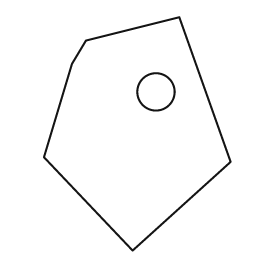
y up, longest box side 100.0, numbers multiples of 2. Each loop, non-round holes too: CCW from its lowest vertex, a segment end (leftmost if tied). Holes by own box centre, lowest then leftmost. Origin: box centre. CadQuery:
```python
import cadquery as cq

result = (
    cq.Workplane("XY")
    .moveTo(-2.0, -50.0)
    .lineTo(40.0, -12.0)
    .lineTo(18.0, 50.0)
    .lineTo(-22.0, 40.0)
    .lineTo(-28.0, 30.0)
    .lineTo(-40.0, -10.0)
    .close()
    .moveTo(8.0, 18.0)
    .circle(8.0)
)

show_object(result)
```